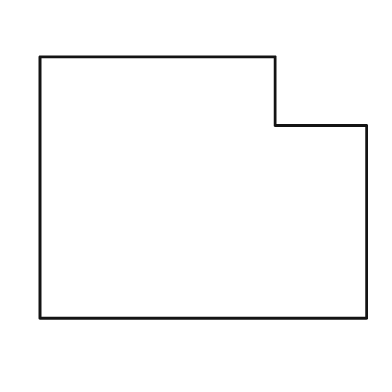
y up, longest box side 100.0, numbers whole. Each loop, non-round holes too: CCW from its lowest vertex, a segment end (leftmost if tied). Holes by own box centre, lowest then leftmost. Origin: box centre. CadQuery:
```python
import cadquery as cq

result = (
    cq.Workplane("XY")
    .moveTo(-50.0, -40.0)
    .lineTo(50.0, -40.0)
    .lineTo(50.0, 19.0)
    .lineTo(22.0, 19.0)
    .lineTo(22.0, 40.0)
    .lineTo(-50.0, 40.0)
    .close()
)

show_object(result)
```